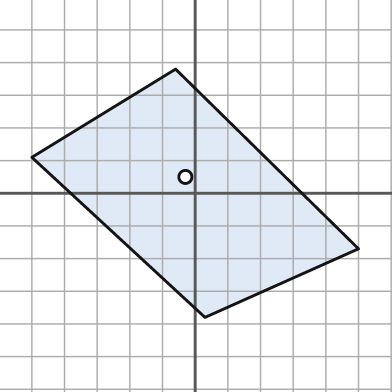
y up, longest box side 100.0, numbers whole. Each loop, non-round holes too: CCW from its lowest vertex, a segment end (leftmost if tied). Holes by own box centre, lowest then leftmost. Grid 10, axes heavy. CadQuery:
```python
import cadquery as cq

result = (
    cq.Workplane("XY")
    .moveTo(3.0, -38.0)
    .lineTo(50.0, -17.0)
    .lineTo(-6.0, 38.0)
    .lineTo(-50.0, 11.0)
    .close()
    .moveTo(-3.0, 5.0)
    .circle(2.0)
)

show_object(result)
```